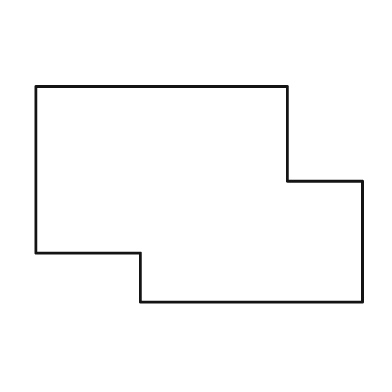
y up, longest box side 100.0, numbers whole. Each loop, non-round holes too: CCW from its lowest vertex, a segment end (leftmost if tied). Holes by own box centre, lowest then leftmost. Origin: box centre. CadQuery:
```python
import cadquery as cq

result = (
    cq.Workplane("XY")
    .moveTo(-18.0, -33.0)
    .lineTo(50.0, -33.0)
    .lineTo(50.0, 4.0)
    .lineTo(27.0, 4.0)
    .lineTo(27.0, 33.0)
    .lineTo(-50.0, 33.0)
    .lineTo(-50.0, -18.0)
    .lineTo(-18.0, -18.0)
    .close()
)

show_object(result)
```